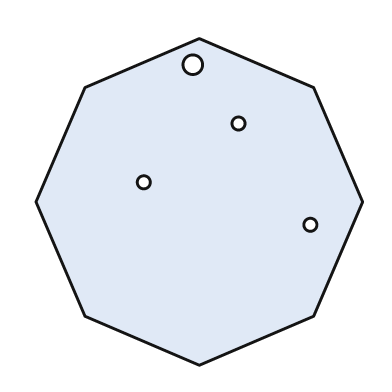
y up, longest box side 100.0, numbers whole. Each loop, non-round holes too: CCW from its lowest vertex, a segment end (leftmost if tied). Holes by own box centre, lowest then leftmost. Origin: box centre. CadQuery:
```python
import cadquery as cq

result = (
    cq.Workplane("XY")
    .moveTo(0.0, -50.0)
    .lineTo(35.0, -35.0)
    .lineTo(50.0, 0.0)
    .lineTo(35.0, 35.0)
    .lineTo(0.0, 50.0)
    .lineTo(-35.0, 35.0)
    .lineTo(-50.0, 0.0)
    .lineTo(-35.0, -35.0)
    .close()
    .moveTo(34.0, -7.0)
    .circle(2.0)
    .moveTo(-17.0, 6.0)
    .circle(2.0)
    .moveTo(12.0, 24.0)
    .circle(2.0)
    .moveTo(-2.0, 42.0)
    .circle(3.0)
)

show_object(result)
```